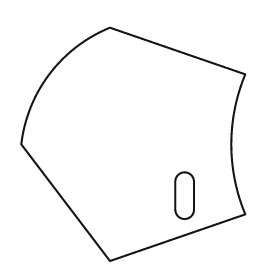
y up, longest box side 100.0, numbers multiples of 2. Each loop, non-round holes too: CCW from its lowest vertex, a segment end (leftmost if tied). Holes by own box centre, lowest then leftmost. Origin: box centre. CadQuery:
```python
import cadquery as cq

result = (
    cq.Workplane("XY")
    .moveTo(-10.0, -50.0)
    .lineTo(48.0, -30.0)
    .threePointArc((42.0, 0.0), (48.0, 30.0))
    .lineTo(-10.0, 50.0)
    .threePointArc((-36.0, 30.0), (-48.0, 0.0))
    .close()
    .moveTo(18.0, -28.0)
    .threePointArc((22.0, -32.0), (26.0, -28.0))
    .lineTo(26.0, -16.0)
    .threePointArc((22.0, -12.0), (18.0, -16.0))
    .close()
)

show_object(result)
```